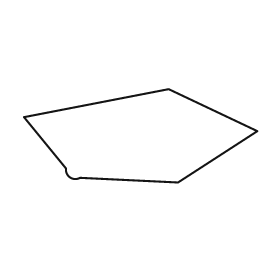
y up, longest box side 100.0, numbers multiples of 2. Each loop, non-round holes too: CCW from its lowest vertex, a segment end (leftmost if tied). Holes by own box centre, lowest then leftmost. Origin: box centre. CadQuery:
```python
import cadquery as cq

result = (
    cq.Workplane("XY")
    .moveTo(16.0, -20.0)
    .lineTo(50.0, 2.0)
    .lineTo(12.0, 20.0)
    .lineTo(-50.0, 8.0)
    .lineTo(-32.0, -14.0)
    .threePointArc((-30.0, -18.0), (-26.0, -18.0))
    .close()
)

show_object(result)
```